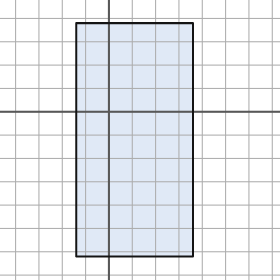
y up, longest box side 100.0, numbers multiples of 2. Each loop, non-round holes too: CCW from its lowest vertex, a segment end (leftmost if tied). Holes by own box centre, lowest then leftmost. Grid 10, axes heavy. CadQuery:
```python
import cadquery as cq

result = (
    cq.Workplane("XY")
    .moveTo(-14.0, -62.0)
    .lineTo(36.0, -62.0)
    .lineTo(36.0, 38.0)
    .lineTo(-14.0, 38.0)
    .close()
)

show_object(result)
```